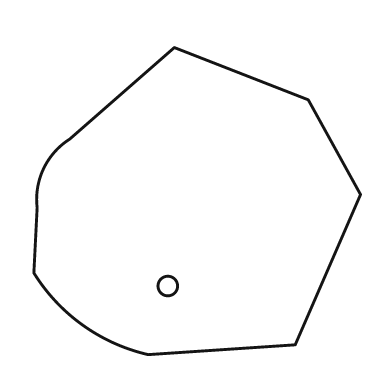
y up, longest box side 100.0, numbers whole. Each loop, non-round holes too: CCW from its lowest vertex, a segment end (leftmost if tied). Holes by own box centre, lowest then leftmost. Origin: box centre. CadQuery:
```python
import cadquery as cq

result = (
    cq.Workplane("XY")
    .moveTo(-15.0, -47.0)
    .lineTo(30.0, -44.0)
    .lineTo(50.0, 2.0)
    .lineTo(34.0, 31.0)
    .lineTo(-7.0, 47.0)
    .lineTo(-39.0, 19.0)
    .threePointArc((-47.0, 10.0), (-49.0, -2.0))
    .lineTo(-50.0, -22.0)
    .threePointArc((-35.0, -38.0), (-15.0, -47.0))
    .close()
    .moveTo(-9.0, -26.0)
    .circle(3.0)
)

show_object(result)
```